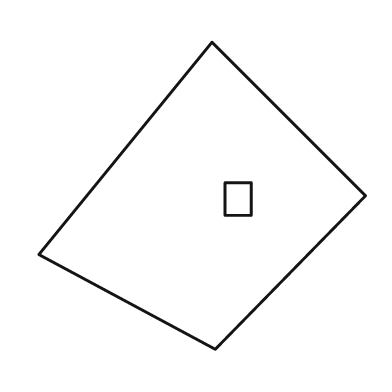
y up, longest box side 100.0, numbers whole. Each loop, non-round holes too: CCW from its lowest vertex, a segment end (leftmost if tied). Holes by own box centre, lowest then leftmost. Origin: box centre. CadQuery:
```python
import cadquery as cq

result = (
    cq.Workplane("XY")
    .moveTo(4.0, -47.0)
    .lineTo(50.0, 0.0)
    .lineTo(3.0, 47.0)
    .lineTo(-50.0, -18.0)
    .close()
    .moveTo(7.0, -6.0)
    .lineTo(15.0, -6.0)
    .lineTo(15.0, 4.0)
    .lineTo(7.0, 4.0)
    .close()
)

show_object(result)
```